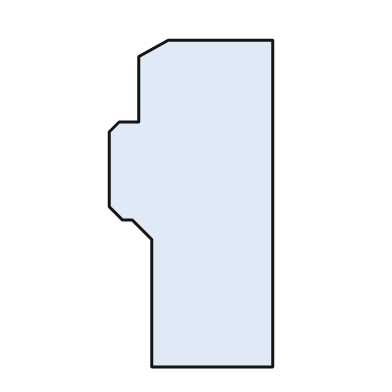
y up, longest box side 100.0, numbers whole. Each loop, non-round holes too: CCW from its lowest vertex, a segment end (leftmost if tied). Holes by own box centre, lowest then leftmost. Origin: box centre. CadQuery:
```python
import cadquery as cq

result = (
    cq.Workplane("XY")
    .moveTo(-12.0, -50.0)
    .lineTo(25.0, -50.0)
    .lineTo(25.0, 50.0)
    .lineTo(-7.0, 50.0)
    .lineTo(-16.0, 45.0)
    .lineTo(-16.0, 25.0)
    .lineTo(-22.0, 25.0)
    .lineTo(-25.0, 22.0)
    .lineTo(-25.0, -1.0)
    .lineTo(-21.0, -5.0)
    .lineTo(-18.0, -5.0)
    .lineTo(-12.0, -11.0)
    .close()
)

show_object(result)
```